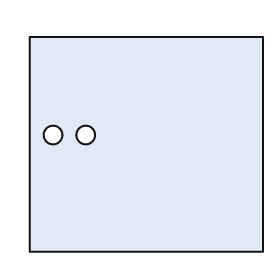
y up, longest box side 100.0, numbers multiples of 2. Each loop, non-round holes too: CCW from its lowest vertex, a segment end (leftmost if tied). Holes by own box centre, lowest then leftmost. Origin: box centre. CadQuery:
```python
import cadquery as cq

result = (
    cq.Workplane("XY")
    .moveTo(-50.0, -46.0)
    .lineTo(50.0, -46.0)
    .lineTo(50.0, 46.0)
    .lineTo(-50.0, 46.0)
    .close()
    .moveTo(-40.0, 4.0)
    .circle(4.0)
    .moveTo(-26.0, 4.0)
    .circle(4.0)
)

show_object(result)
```